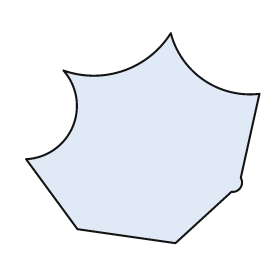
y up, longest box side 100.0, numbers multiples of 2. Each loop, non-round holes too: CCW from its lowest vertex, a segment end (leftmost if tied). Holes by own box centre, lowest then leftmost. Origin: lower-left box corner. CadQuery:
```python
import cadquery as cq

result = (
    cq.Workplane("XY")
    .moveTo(64.0, 0.0)
    .lineTo(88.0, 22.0)
    .threePointArc((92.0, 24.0), (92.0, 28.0))
    .lineTo(100.0, 64.0)
    .threePointArc((76.0, 70.0), (62.0, 90.0))
    .threePointArc((42.0, 74.0), (16.0, 74.0))
    .threePointArc((20.0, 50.0), (0.0, 36.0))
    .lineTo(22.0, 6.0)
    .close()
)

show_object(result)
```